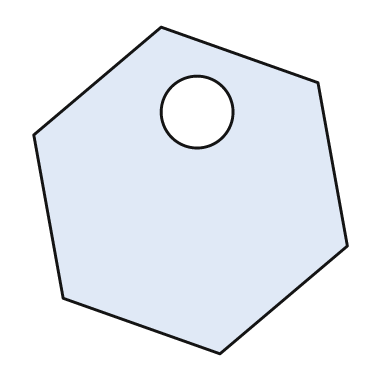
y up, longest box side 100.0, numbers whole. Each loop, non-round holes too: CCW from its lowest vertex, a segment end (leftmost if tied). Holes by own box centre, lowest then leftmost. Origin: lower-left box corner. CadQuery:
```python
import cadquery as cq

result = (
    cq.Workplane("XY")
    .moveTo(57.0, 0.0)
    .lineTo(96.0, 33.0)
    .lineTo(87.0, 83.0)
    .lineTo(39.0, 100.0)
    .lineTo(0.0, 67.0)
    .lineTo(9.0, 17.0)
    .close()
    .moveTo(50.0, 74.0)
    .circle(11.0)
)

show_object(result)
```